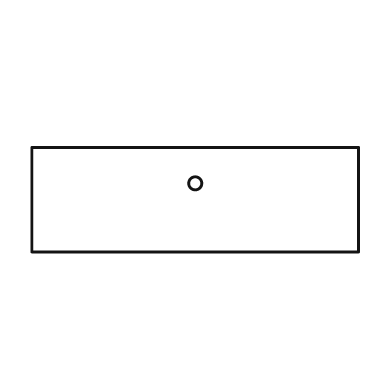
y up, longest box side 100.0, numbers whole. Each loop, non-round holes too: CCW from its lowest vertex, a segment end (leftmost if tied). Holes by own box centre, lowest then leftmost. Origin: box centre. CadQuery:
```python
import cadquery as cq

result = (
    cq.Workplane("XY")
    .moveTo(-50.0, -16.0)
    .lineTo(50.0, -16.0)
    .lineTo(50.0, 16.0)
    .lineTo(-50.0, 16.0)
    .close()
    .moveTo(0.0, 5.0)
    .circle(2.0)
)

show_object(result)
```